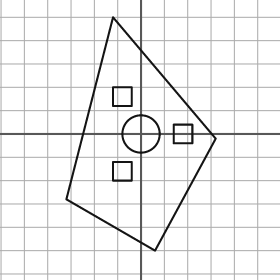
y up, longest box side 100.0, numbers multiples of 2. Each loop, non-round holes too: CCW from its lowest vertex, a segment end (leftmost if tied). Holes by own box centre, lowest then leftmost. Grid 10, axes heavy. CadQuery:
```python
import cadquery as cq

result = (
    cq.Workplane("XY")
    .moveTo(6.0, -50.0)
    .lineTo(32.0, -2.0)
    .lineTo(-12.0, 50.0)
    .lineTo(-32.0, -28.0)
    .close()
    .moveTo(-12.0, -20.0)
    .lineTo(-4.0, -20.0)
    .lineTo(-4.0, -12.0)
    .lineTo(-12.0, -12.0)
    .close()
    .moveTo(0.0, 0.0)
    .circle(8.0)
    .moveTo(14.0, -4.0)
    .lineTo(22.0, -4.0)
    .lineTo(22.0, 4.0)
    .lineTo(14.0, 4.0)
    .close()
    .moveTo(-12.0, 12.0)
    .lineTo(-4.0, 12.0)
    .lineTo(-4.0, 20.0)
    .lineTo(-12.0, 20.0)
    .close()
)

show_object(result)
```